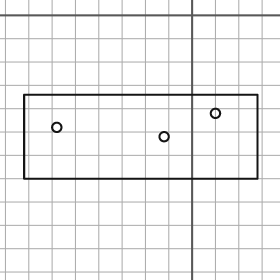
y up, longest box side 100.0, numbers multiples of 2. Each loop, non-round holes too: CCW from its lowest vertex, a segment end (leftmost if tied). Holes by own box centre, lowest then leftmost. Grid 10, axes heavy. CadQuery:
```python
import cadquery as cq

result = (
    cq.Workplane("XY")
    .moveTo(-72.0, -70.0)
    .lineTo(28.0, -70.0)
    .lineTo(28.0, -34.0)
    .lineTo(-72.0, -34.0)
    .close()
    .moveTo(-12.0, -52.0)
    .circle(2.0)
    .moveTo(-58.0, -48.0)
    .circle(2.0)
    .moveTo(10.0, -42.0)
    .circle(2.0)
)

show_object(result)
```